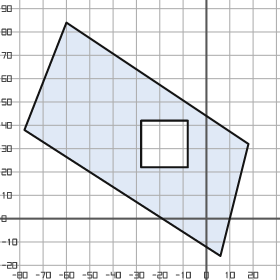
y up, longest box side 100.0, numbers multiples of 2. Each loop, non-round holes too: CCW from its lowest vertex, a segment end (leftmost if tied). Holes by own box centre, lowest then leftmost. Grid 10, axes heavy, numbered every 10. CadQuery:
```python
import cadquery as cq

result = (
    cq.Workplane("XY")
    .moveTo(6.0, -16.0)
    .lineTo(18.0, 32.0)
    .lineTo(-60.0, 84.0)
    .lineTo(-78.0, 38.0)
    .close()
    .moveTo(-28.0, 22.0)
    .lineTo(-8.0, 22.0)
    .lineTo(-8.0, 42.0)
    .lineTo(-28.0, 42.0)
    .close()
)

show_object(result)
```